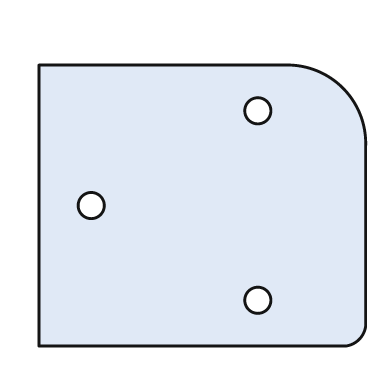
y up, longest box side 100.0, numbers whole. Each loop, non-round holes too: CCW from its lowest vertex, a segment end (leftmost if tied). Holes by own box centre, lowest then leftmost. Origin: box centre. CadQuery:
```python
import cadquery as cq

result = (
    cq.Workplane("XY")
    .moveTo(-50.0, -43.0)
    .lineTo(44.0, -43.0)
    .threePointArc((48.0, -41.0), (50.0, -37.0))
    .lineTo(50.0, 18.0)
    .threePointArc((43.0, 36.0), (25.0, 43.0))
    .lineTo(-50.0, 43.0)
    .close()
    .moveTo(17.0, -29.0)
    .circle(4.0)
    .moveTo(-34.0, 0.0)
    .circle(4.0)
    .moveTo(17.0, 29.0)
    .circle(4.0)
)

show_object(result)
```